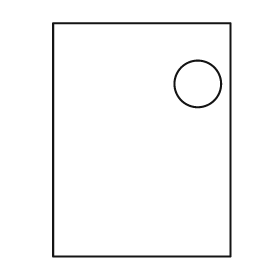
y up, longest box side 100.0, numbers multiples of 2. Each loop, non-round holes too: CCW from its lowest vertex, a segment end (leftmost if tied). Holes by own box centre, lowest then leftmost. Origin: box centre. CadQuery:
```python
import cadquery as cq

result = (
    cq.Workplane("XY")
    .moveTo(-38.0, -50.0)
    .lineTo(38.0, -50.0)
    .lineTo(38.0, 50.0)
    .lineTo(-38.0, 50.0)
    .close()
    .moveTo(24.0, 24.0)
    .circle(10.0)
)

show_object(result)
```